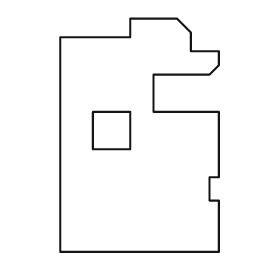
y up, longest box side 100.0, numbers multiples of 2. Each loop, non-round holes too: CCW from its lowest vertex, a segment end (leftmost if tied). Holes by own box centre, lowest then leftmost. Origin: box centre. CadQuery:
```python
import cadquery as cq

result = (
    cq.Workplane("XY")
    .moveTo(-34.0, -50.0)
    .lineTo(34.0, -50.0)
    .lineTo(34.0, -28.0)
    .lineTo(30.0, -28.0)
    .lineTo(30.0, -18.0)
    .lineTo(34.0, -18.0)
    .lineTo(34.0, 10.0)
    .lineTo(6.0, 10.0)
    .lineTo(6.0, 26.0)
    .lineTo(30.0, 26.0)
    .lineTo(34.0, 30.0)
    .lineTo(34.0, 36.0)
    .lineTo(22.0, 36.0)
    .lineTo(22.0, 44.0)
    .lineTo(16.0, 50.0)
    .lineTo(-4.0, 50.0)
    .lineTo(-4.0, 42.0)
    .lineTo(-34.0, 42.0)
    .close()
    .moveTo(-20.0, -6.0)
    .lineTo(-4.0, -6.0)
    .lineTo(-4.0, 10.0)
    .lineTo(-20.0, 10.0)
    .close()
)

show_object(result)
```